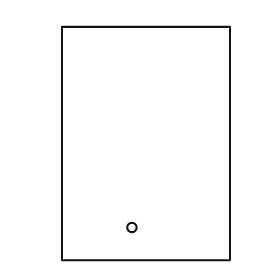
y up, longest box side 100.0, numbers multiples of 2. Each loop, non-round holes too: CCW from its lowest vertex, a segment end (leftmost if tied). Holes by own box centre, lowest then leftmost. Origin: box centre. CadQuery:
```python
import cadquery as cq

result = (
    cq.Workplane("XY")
    .moveTo(-36.0, -50.0)
    .lineTo(36.0, -50.0)
    .lineTo(36.0, 50.0)
    .lineTo(-36.0, 50.0)
    .close()
    .moveTo(-6.0, -36.0)
    .circle(2.0)
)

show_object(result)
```